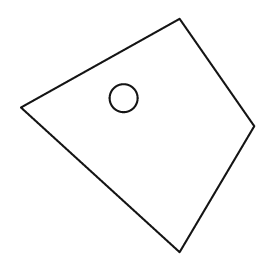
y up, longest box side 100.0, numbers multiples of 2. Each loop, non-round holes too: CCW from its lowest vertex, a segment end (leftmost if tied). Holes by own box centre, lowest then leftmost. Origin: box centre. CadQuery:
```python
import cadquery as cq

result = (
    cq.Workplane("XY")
    .moveTo(18.0, -50.0)
    .lineTo(50.0, 4.0)
    .lineTo(18.0, 50.0)
    .lineTo(-50.0, 12.0)
    .close()
    .moveTo(-6.0, 16.0)
    .circle(6.0)
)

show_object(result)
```